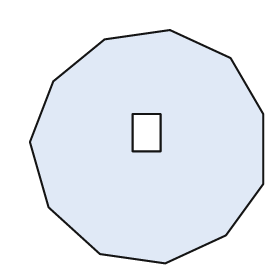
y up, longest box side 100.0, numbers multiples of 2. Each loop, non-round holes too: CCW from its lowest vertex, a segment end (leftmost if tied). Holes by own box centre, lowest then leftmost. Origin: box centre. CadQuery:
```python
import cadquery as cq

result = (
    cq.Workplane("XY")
    .moveTo(8.0, -50.0)
    .lineTo(34.0, -38.0)
    .lineTo(50.0, -16.0)
    .lineTo(50.0, 14.0)
    .lineTo(36.0, 38.0)
    .lineTo(10.0, 50.0)
    .lineTo(-18.0, 46.0)
    .lineTo(-40.0, 28.0)
    .lineTo(-50.0, 2.0)
    .lineTo(-42.0, -26.0)
    .lineTo(-20.0, -46.0)
    .close()
    .moveTo(-6.0, -2.0)
    .lineTo(6.0, -2.0)
    .lineTo(6.0, 14.0)
    .lineTo(-6.0, 14.0)
    .close()
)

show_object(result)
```